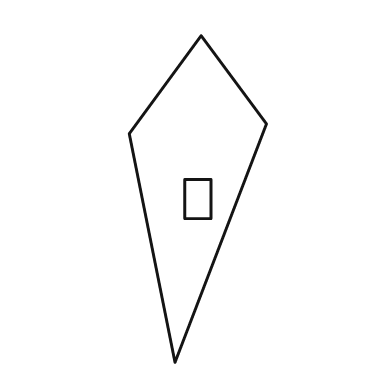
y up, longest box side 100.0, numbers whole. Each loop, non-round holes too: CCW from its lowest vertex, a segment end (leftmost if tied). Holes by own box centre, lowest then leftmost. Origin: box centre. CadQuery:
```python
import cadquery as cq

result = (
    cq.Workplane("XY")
    .moveTo(-7.0, -50.0)
    .lineTo(21.0, 23.0)
    .lineTo(1.0, 50.0)
    .lineTo(-21.0, 20.0)
    .close()
    .moveTo(-4.0, -6.0)
    .lineTo(4.0, -6.0)
    .lineTo(4.0, 6.0)
    .lineTo(-4.0, 6.0)
    .close()
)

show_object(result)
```